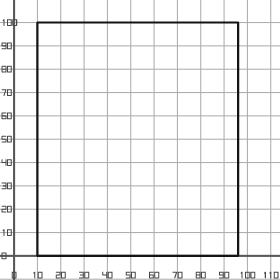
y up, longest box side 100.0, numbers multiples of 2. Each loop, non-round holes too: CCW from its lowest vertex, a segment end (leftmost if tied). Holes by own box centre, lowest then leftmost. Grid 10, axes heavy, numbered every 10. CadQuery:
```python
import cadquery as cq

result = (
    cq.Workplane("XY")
    .moveTo(10.0, 0.0)
    .lineTo(96.0, 0.0)
    .lineTo(96.0, 100.0)
    .lineTo(10.0, 100.0)
    .close()
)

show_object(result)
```